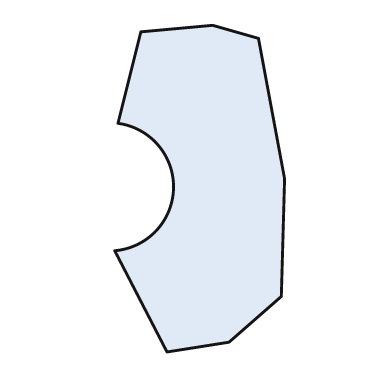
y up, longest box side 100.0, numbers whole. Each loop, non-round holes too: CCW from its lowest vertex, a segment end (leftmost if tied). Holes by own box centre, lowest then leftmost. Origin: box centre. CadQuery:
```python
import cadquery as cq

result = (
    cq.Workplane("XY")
    .moveTo(-10.0, -50.0)
    .lineTo(9.0, -47.0)
    .lineTo(25.0, -33.0)
    .lineTo(26.0, 3.0)
    .lineTo(18.0, 46.0)
    .lineTo(4.0, 50.0)
    .lineTo(-18.0, 48.0)
    .lineTo(-25.0, 20.0)
    .threePointArc((-8.0, 0.0), (-26.0, -19.0))
    .close()
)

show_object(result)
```